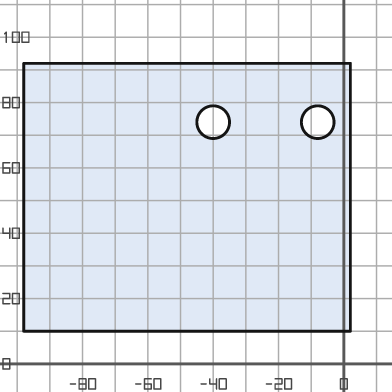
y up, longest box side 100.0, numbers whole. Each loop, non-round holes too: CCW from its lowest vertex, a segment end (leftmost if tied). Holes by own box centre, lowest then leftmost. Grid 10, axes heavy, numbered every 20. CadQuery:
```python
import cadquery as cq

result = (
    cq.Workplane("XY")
    .moveTo(-98.0, 10.0)
    .lineTo(2.0, 10.0)
    .lineTo(2.0, 92.0)
    .lineTo(-98.0, 92.0)
    .close()
    .moveTo(-40.0, 74.0)
    .circle(5.0)
    .moveTo(-8.0, 74.0)
    .circle(5.0)
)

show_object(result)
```